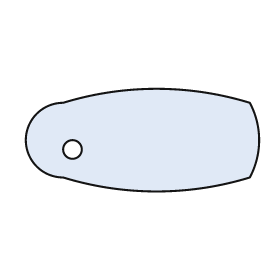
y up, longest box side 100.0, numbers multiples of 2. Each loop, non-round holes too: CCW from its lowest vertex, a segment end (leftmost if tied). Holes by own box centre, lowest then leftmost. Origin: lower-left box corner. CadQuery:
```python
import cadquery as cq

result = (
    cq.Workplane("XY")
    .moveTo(16.0, 6.0)
    .threePointArc((56.0, 0.0), (96.0, 6.0))
    .threePointArc((100.0, 22.0), (96.0, 38.0))
    .threePointArc((56.0, 44.0), (16.0, 38.0))
    .threePointArc((0.0, 22.0), (16.0, 6.0))
    .close()
    .moveTo(20.0, 18.0)
    .circle(4.0)
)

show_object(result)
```